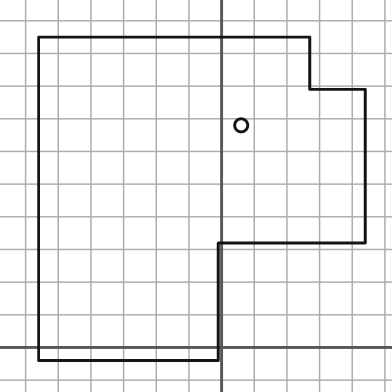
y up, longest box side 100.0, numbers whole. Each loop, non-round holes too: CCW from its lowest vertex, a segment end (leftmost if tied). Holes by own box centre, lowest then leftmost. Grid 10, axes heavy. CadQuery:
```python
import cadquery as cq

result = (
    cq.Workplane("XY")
    .moveTo(-56.0, -4.0)
    .lineTo(-1.0, -4.0)
    .lineTo(-1.0, 32.0)
    .lineTo(44.0, 32.0)
    .lineTo(44.0, 79.0)
    .lineTo(27.0, 79.0)
    .lineTo(27.0, 95.0)
    .lineTo(-56.0, 95.0)
    .close()
    .moveTo(6.0, 68.0)
    .circle(2.0)
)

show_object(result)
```